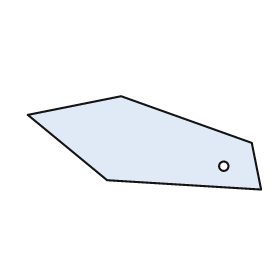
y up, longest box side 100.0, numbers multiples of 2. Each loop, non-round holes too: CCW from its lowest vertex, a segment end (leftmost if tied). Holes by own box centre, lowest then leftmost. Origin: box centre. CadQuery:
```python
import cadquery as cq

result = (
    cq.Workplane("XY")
    .moveTo(50.0, -20.0)
    .lineTo(46.0, 0.0)
    .lineTo(-10.0, 20.0)
    .lineTo(-50.0, 12.0)
    .lineTo(-16.0, -16.0)
    .close()
    .moveTo(34.0, -10.0)
    .circle(2.0)
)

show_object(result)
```